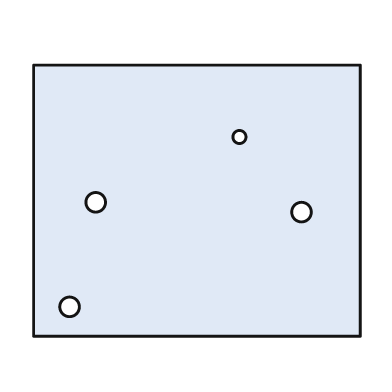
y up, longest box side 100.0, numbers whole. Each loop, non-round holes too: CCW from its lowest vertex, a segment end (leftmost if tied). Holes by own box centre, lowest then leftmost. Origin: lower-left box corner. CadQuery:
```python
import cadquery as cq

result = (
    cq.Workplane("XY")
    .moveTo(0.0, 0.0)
    .lineTo(100.0, 0.0)
    .lineTo(100.0, 83.0)
    .lineTo(0.0, 83.0)
    .close()
    .moveTo(11.0, 9.0)
    .circle(3.0)
    .moveTo(82.0, 38.0)
    .circle(3.0)
    .moveTo(19.0, 41.0)
    .circle(3.0)
    .moveTo(63.0, 61.0)
    .circle(2.0)
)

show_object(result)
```